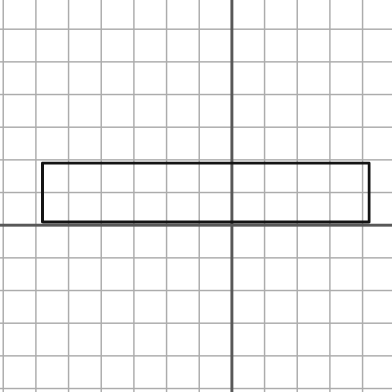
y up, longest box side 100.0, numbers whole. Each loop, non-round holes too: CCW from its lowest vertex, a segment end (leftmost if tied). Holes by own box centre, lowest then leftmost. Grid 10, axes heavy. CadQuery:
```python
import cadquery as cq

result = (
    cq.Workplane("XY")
    .moveTo(-58.0, 1.0)
    .lineTo(42.0, 1.0)
    .lineTo(42.0, 19.0)
    .lineTo(-58.0, 19.0)
    .close()
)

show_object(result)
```